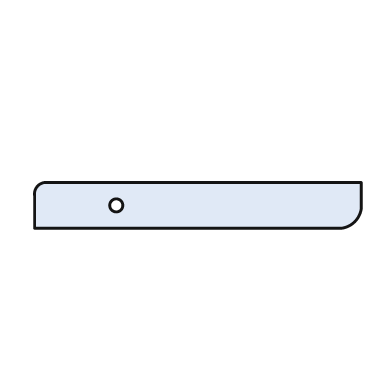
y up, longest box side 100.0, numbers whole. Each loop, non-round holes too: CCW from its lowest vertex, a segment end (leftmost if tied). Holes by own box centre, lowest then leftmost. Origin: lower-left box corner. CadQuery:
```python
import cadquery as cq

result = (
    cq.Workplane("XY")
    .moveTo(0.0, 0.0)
    .lineTo(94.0, 0.0)
    .threePointArc((98.0, 2.0), (100.0, 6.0))
    .lineTo(100.0, 14.0)
    .lineTo(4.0, 14.0)
    .threePointArc((1.0, 13.0), (0.0, 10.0))
    .close()
    .moveTo(25.0, 7.0)
    .circle(2.0)
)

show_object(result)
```